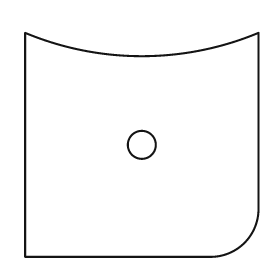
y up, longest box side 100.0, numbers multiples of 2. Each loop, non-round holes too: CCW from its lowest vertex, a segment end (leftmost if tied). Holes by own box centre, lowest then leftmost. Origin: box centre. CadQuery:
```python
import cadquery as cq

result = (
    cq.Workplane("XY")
    .moveTo(-50.0, -48.0)
    .lineTo(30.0, -48.0)
    .threePointArc((44.0, -42.0), (50.0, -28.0))
    .lineTo(50.0, 48.0)
    .threePointArc((0.0, 38.0), (-50.0, 48.0))
    .close()
    .moveTo(0.0, 0.0)
    .circle(6.0)
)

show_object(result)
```